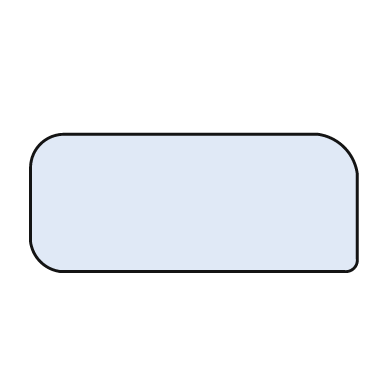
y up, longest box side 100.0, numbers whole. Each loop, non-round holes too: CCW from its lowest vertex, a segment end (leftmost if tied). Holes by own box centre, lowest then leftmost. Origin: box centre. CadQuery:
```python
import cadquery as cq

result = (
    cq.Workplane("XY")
    .moveTo(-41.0, -21.0)
    .lineTo(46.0, -21.0)
    .threePointArc((49.0, -20.0), (50.0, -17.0))
    .lineTo(50.0, 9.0)
    .threePointArc((46.0, 17.0), (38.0, 21.0))
    .lineTo(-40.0, 21.0)
    .threePointArc((-47.0, 18.0), (-50.0, 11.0))
    .lineTo(-50.0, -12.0)
    .threePointArc((-47.0, -18.0), (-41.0, -21.0))
    .close()
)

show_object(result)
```